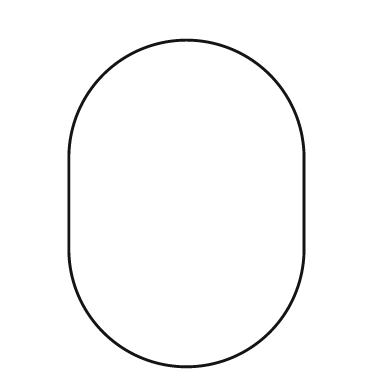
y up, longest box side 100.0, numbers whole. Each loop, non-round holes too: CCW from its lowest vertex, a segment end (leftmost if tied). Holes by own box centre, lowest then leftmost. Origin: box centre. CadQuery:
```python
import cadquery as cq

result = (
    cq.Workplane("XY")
    .moveTo(-36.0, -14.0)
    .threePointArc((0.0, -50.0), (36.0, -14.0))
    .lineTo(36.0, 14.0)
    .threePointArc((0.0, 50.0), (-36.0, 14.0))
    .close()
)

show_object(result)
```